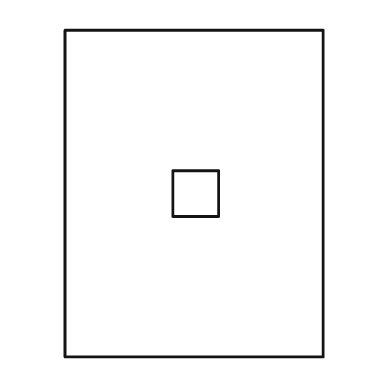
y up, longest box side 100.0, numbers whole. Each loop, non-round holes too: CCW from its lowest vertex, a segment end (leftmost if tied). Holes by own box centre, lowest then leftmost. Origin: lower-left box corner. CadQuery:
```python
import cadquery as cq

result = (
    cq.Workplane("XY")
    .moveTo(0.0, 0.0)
    .lineTo(79.0, 0.0)
    .lineTo(79.0, 100.0)
    .lineTo(0.0, 100.0)
    .close()
    .moveTo(33.0, 43.0)
    .lineTo(47.0, 43.0)
    .lineTo(47.0, 57.0)
    .lineTo(33.0, 57.0)
    .close()
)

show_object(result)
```